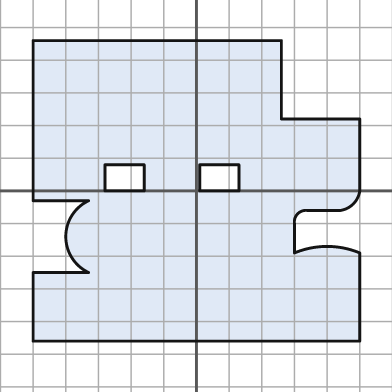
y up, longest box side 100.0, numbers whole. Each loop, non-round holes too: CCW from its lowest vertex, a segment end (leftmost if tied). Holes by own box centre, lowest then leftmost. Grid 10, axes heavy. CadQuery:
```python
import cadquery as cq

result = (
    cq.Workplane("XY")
    .moveTo(-50.0, -46.0)
    .lineTo(50.0, -46.0)
    .lineTo(50.0, -19.0)
    .threePointArc((40.0, -17.0), (30.0, -19.0))
    .lineTo(30.0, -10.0)
    .threePointArc((31.0, -7.0), (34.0, -6.0))
    .lineTo(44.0, -6.0)
    .threePointArc((48.0, -4.0), (50.0, 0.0))
    .lineTo(50.0, 22.0)
    .lineTo(26.0, 22.0)
    .lineTo(26.0, 46.0)
    .lineTo(-50.0, 46.0)
    .lineTo(-50.0, -3.0)
    .lineTo(-33.0, -3.0)
    .threePointArc((-40.0, -14.0), (-33.0, -25.0))
    .lineTo(-50.0, -25.0)
    .close()
    .moveTo(-28.0, 0.0)
    .lineTo(-16.0, 0.0)
    .lineTo(-16.0, 8.0)
    .lineTo(-28.0, 8.0)
    .close()
    .moveTo(1.0, 0.0)
    .lineTo(13.0, 0.0)
    .lineTo(13.0, 8.0)
    .lineTo(1.0, 8.0)
    .close()
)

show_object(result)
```